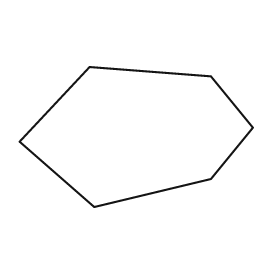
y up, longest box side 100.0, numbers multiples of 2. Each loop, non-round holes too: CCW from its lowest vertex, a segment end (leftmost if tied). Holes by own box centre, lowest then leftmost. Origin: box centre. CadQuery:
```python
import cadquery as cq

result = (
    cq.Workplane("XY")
    .moveTo(-18.0, -30.0)
    .lineTo(32.0, -18.0)
    .lineTo(50.0, 4.0)
    .lineTo(32.0, 26.0)
    .lineTo(-20.0, 30.0)
    .lineTo(-50.0, -2.0)
    .close()
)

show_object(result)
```